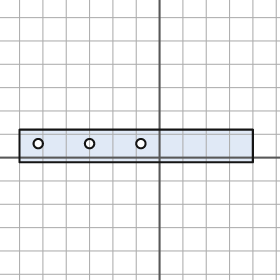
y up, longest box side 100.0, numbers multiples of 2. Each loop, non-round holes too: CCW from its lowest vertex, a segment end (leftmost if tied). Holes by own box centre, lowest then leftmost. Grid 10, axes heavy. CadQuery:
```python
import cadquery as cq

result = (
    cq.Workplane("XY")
    .moveTo(-60.0, -2.0)
    .lineTo(40.0, -2.0)
    .lineTo(40.0, 12.0)
    .lineTo(-60.0, 12.0)
    .close()
    .moveTo(-52.0, 6.0)
    .circle(2.0)
    .moveTo(-30.0, 6.0)
    .circle(2.0)
    .moveTo(-8.0, 6.0)
    .circle(2.0)
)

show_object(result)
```